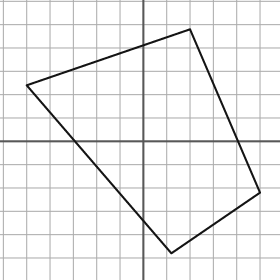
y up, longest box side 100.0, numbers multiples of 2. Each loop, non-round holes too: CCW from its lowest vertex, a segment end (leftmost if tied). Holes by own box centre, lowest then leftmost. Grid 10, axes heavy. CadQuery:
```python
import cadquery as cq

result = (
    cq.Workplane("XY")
    .moveTo(12.0, -48.0)
    .lineTo(50.0, -22.0)
    .lineTo(20.0, 48.0)
    .lineTo(-50.0, 24.0)
    .close()
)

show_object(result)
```